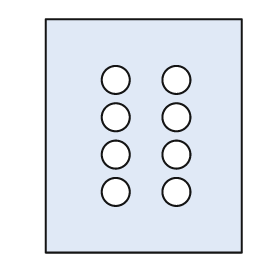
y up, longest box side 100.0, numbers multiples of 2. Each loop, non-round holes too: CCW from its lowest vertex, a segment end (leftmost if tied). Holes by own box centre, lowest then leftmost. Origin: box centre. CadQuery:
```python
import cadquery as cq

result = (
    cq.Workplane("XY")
    .moveTo(-42.0, -50.0)
    .lineTo(42.0, -50.0)
    .lineTo(42.0, 50.0)
    .lineTo(-42.0, 50.0)
    .close()
    .moveTo(-12.0, -24.0)
    .circle(6.0)
    .moveTo(14.0, -24.0)
    .circle(6.0)
    .moveTo(-12.0, -8.0)
    .circle(6.0)
    .moveTo(14.0, -8.0)
    .circle(6.0)
    .moveTo(-12.0, 8.0)
    .circle(6.0)
    .moveTo(14.0, 8.0)
    .circle(6.0)
    .moveTo(-12.0, 24.0)
    .circle(6.0)
    .moveTo(14.0, 24.0)
    .circle(6.0)
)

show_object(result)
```